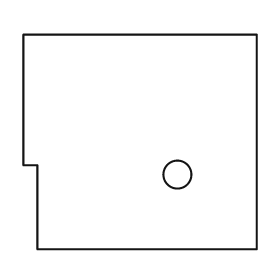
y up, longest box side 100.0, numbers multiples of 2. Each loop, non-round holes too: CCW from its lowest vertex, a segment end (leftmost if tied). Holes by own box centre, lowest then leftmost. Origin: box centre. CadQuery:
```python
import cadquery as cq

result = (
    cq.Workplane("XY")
    .moveTo(-44.0, -46.0)
    .lineTo(50.0, -46.0)
    .lineTo(50.0, 46.0)
    .lineTo(-50.0, 46.0)
    .lineTo(-50.0, -10.0)
    .lineTo(-44.0, -10.0)
    .close()
    .moveTo(16.0, -14.0)
    .circle(6.0)
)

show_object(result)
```